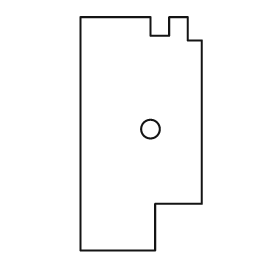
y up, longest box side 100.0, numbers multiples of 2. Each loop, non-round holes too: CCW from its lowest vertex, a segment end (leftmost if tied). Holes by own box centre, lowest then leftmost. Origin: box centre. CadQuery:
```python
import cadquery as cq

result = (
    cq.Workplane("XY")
    .moveTo(-26.0, -50.0)
    .lineTo(6.0, -50.0)
    .lineTo(6.0, -30.0)
    .lineTo(26.0, -30.0)
    .lineTo(26.0, 40.0)
    .lineTo(20.0, 40.0)
    .lineTo(20.0, 50.0)
    .lineTo(12.0, 50.0)
    .lineTo(12.0, 42.0)
    .lineTo(4.0, 42.0)
    .lineTo(4.0, 50.0)
    .lineTo(-26.0, 50.0)
    .close()
    .moveTo(4.0, 2.0)
    .circle(4.0)
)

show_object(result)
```